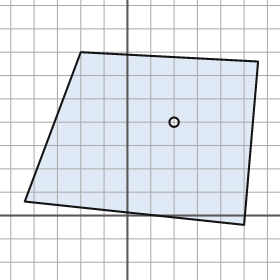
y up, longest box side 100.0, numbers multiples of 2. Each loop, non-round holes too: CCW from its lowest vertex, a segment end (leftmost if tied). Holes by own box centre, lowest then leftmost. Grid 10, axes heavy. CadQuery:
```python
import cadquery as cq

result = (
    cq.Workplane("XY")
    .moveTo(50.0, -4.0)
    .lineTo(56.0, 66.0)
    .lineTo(-20.0, 70.0)
    .lineTo(-44.0, 6.0)
    .close()
    .moveTo(20.0, 40.0)
    .circle(2.0)
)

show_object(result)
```